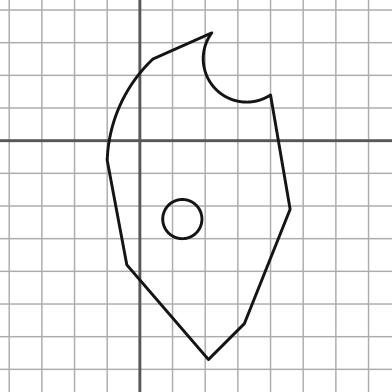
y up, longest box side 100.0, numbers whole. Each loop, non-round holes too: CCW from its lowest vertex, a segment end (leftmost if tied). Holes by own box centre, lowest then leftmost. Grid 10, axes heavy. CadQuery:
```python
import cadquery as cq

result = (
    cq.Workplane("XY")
    .moveTo(21.0, -67.0)
    .lineTo(32.0, -56.0)
    .lineTo(46.0, -21.0)
    .lineTo(40.0, 14.0)
    .threePointArc((23.0, 16.0), (22.0, 33.0))
    .lineTo(4.0, 25.0)
    .threePointArc((-6.0, 11.0), (-10.0, -6.0))
    .lineTo(-4.0, -38.0)
    .close()
    .moveTo(13.0, -24.0)
    .circle(6.0)
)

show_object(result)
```